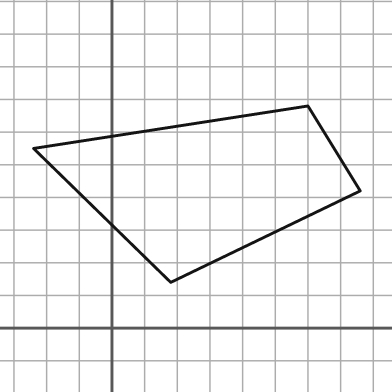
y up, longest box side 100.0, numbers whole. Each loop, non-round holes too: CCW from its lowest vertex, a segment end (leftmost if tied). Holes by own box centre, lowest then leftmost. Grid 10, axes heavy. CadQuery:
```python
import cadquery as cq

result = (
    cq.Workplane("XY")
    .moveTo(18.0, 14.0)
    .lineTo(76.0, 42.0)
    .lineTo(60.0, 68.0)
    .lineTo(-24.0, 55.0)
    .close()
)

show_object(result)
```